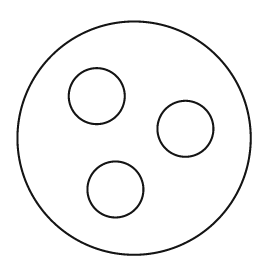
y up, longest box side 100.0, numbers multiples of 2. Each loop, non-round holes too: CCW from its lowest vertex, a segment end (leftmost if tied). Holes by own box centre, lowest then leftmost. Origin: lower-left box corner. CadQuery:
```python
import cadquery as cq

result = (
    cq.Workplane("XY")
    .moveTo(50.0, 50.0)
    .circle(50.0)
    .moveTo(42.0, 28.0)
    .circle(12.0)
    .moveTo(72.0, 54.0)
    .circle(12.0)
    .moveTo(34.0, 68.0)
    .circle(12.0)
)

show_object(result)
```